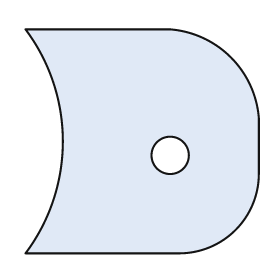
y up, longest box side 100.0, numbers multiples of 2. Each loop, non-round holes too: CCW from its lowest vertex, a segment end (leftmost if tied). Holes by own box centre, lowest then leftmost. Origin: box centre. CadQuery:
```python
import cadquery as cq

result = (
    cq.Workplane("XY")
    .moveTo(-50.0, -48.0)
    .lineTo(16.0, -48.0)
    .threePointArc((40.0, -38.0), (50.0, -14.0))
    .lineTo(50.0, 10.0)
    .threePointArc((38.0, 36.0), (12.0, 48.0))
    .lineTo(-50.0, 48.0)
    .threePointArc((-34.0, 0.0), (-50.0, -48.0))
    .close()
    .moveTo(12.0, -6.0)
    .circle(8.0)
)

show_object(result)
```